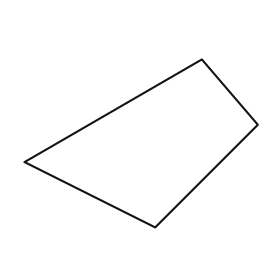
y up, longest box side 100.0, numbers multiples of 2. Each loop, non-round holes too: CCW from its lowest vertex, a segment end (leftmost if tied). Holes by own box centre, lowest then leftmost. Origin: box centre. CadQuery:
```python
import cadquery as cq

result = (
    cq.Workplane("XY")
    .moveTo(6.0, -36.0)
    .lineTo(50.0, 8.0)
    .lineTo(26.0, 36.0)
    .lineTo(-50.0, -8.0)
    .close()
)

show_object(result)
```